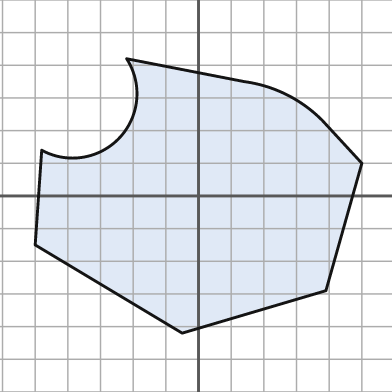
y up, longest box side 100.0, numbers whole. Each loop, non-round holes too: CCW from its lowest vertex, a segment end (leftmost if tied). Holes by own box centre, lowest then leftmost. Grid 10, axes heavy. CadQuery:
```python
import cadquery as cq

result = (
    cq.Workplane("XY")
    .moveTo(-5.0, -42.0)
    .lineTo(39.0, -29.0)
    .lineTo(50.0, 10.0)
    .lineTo(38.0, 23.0)
    .threePointArc((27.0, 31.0), (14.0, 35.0))
    .lineTo(-22.0, 42.0)
    .threePointArc((-24.0, 18.0), (-48.0, 14.0))
    .lineTo(-50.0, -15.0)
    .close()
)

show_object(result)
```